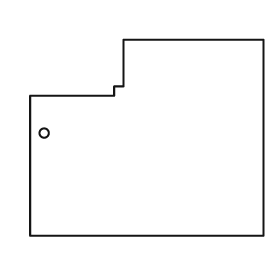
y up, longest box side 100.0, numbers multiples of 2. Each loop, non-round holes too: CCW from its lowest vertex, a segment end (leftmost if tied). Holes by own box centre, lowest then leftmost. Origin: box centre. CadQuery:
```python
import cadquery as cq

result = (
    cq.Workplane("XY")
    .moveTo(-50.0, -42.0)
    .lineTo(50.0, -42.0)
    .lineTo(50.0, 42.0)
    .lineTo(-10.0, 42.0)
    .lineTo(-10.0, 22.0)
    .lineTo(-14.0, 22.0)
    .lineTo(-14.0, 18.0)
    .lineTo(-50.0, 18.0)
    .close()
    .moveTo(-44.0, 2.0)
    .circle(2.0)
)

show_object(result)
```